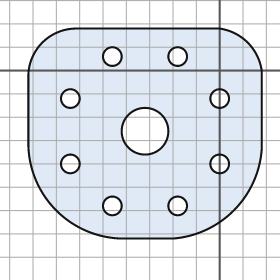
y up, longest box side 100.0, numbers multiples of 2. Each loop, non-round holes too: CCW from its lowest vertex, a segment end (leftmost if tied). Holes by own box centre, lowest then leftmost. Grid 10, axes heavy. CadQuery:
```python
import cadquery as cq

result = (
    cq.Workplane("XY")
    .moveTo(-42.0, -72.0)
    .lineTo(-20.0, -72.0)
    .threePointArc((6.0, -60.0), (18.0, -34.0))
    .lineTo(18.0, 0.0)
    .threePointArc((12.0, 12.0), (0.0, 18.0))
    .lineTo(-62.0, 18.0)
    .threePointArc((-76.0, 12.0), (-82.0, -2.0))
    .lineTo(-82.0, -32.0)
    .threePointArc((-70.0, -60.0), (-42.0, -72.0))
    .close()
    .moveTo(-46.0, -58.0)
    .circle(4.0)
    .moveTo(-18.0, -58.0)
    .circle(4.0)
    .moveTo(-64.0, -40.0)
    .circle(4.0)
    .moveTo(0.0, -40.0)
    .circle(4.0)
    .moveTo(-32.0, -26.0)
    .circle(10.0)
    .moveTo(-64.0, -12.0)
    .circle(4.0)
    .moveTo(0.0, -12.0)
    .circle(4.0)
    .moveTo(-46.0, 6.0)
    .circle(4.0)
    .moveTo(-18.0, 6.0)
    .circle(4.0)
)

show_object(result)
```